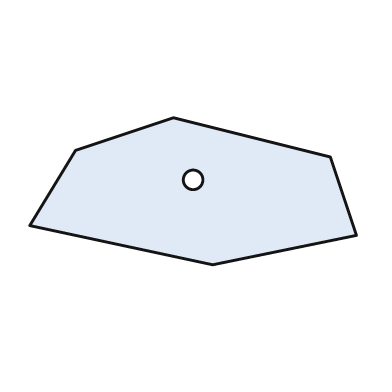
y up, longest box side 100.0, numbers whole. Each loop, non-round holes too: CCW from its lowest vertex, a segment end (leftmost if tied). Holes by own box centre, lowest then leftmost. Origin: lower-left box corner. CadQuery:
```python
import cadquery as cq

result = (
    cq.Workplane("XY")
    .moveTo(56.0, 0.0)
    .lineTo(100.0, 9.0)
    .lineTo(92.0, 33.0)
    .lineTo(44.0, 45.0)
    .lineTo(14.0, 35.0)
    .lineTo(0.0, 12.0)
    .close()
    .moveTo(50.0, 26.0)
    .circle(3.0)
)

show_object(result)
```